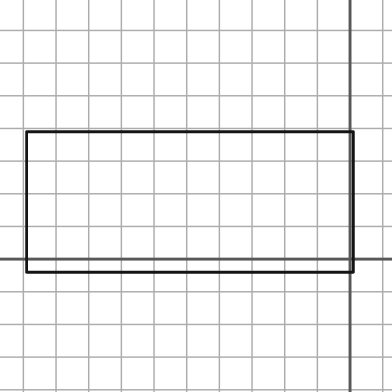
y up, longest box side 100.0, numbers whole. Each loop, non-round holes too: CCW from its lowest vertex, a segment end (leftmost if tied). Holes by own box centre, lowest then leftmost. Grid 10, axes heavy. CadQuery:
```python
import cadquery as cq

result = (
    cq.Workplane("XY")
    .moveTo(-99.0, -4.0)
    .lineTo(1.0, -4.0)
    .lineTo(1.0, 39.0)
    .lineTo(-99.0, 39.0)
    .close()
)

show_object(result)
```